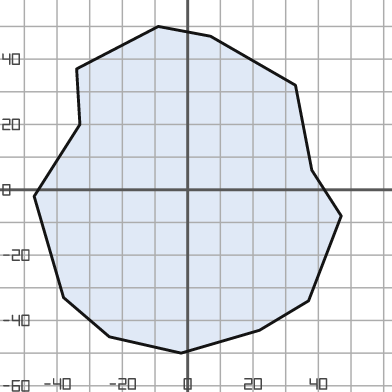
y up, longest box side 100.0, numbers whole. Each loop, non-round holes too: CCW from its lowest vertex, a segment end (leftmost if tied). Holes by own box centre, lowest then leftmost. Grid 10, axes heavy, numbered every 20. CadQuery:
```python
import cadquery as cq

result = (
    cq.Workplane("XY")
    .moveTo(-2.0, -50.0)
    .lineTo(22.0, -43.0)
    .lineTo(37.0, -34.0)
    .lineTo(47.0, -8.0)
    .lineTo(38.0, 6.0)
    .lineTo(33.0, 32.0)
    .lineTo(7.0, 47.0)
    .lineTo(-9.0, 50.0)
    .lineTo(-34.0, 37.0)
    .lineTo(-33.0, 20.0)
    .lineTo(-47.0, -2.0)
    .lineTo(-38.0, -33.0)
    .lineTo(-24.0, -45.0)
    .close()
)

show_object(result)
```